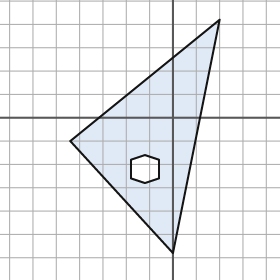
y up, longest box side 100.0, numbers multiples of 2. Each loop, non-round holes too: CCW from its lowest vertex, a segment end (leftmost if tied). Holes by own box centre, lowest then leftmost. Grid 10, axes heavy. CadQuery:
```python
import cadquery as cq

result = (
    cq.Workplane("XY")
    .moveTo(0.0, -58.0)
    .lineTo(20.0, 42.0)
    .lineTo(-44.0, -10.0)
    .close()
    .moveTo(-12.0, -28.0)
    .lineTo(-6.0, -26.0)
    .lineTo(-6.0, -18.0)
    .lineTo(-12.0, -16.0)
    .lineTo(-18.0, -18.0)
    .lineTo(-18.0, -26.0)
    .close()
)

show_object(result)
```